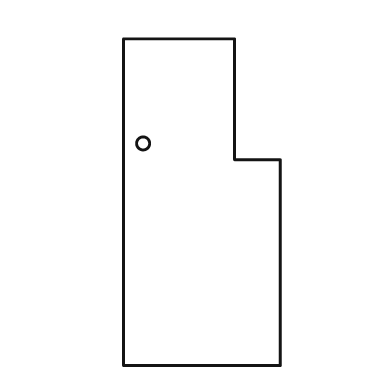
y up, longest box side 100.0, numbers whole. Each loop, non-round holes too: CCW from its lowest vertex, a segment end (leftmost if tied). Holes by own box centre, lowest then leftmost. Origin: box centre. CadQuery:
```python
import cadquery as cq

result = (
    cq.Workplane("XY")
    .moveTo(-24.0, -50.0)
    .lineTo(24.0, -50.0)
    .lineTo(24.0, 13.0)
    .lineTo(10.0, 13.0)
    .lineTo(10.0, 50.0)
    .lineTo(-24.0, 50.0)
    .close()
    .moveTo(-18.0, 18.0)
    .circle(2.0)
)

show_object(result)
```